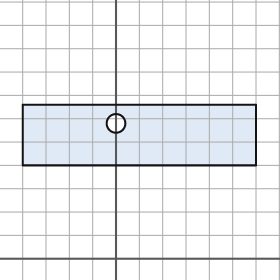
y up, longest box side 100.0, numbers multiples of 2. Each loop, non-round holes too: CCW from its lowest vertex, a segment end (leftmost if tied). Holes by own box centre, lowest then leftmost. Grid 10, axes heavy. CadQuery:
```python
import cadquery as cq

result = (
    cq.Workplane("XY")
    .moveTo(-40.0, 40.0)
    .lineTo(60.0, 40.0)
    .lineTo(60.0, 66.0)
    .lineTo(-40.0, 66.0)
    .close()
    .moveTo(0.0, 58.0)
    .circle(4.0)
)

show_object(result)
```